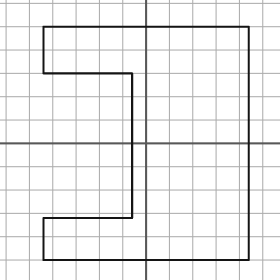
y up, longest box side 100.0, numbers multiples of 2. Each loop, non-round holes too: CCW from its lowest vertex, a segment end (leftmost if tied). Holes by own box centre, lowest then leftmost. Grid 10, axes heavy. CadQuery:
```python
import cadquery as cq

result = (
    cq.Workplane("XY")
    .moveTo(-44.0, -50.0)
    .lineTo(44.0, -50.0)
    .lineTo(44.0, 50.0)
    .lineTo(-44.0, 50.0)
    .lineTo(-44.0, 30.0)
    .lineTo(-6.0, 30.0)
    .lineTo(-6.0, -32.0)
    .lineTo(-44.0, -32.0)
    .close()
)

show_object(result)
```